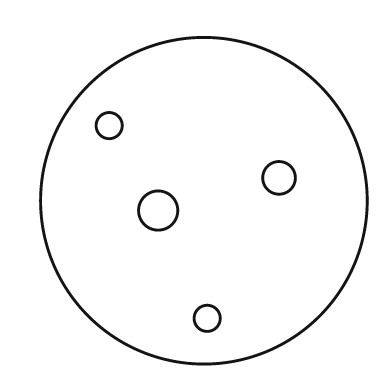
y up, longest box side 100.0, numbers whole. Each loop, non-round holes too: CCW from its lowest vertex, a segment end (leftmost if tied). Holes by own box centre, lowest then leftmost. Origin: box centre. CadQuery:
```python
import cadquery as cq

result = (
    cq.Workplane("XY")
    .moveTo(0.0, 0.0)
    .circle(50.0)
    .moveTo(1.0, -36.0)
    .circle(4.0)
    .moveTo(-14.0, -3.0)
    .circle(6.0)
    .moveTo(23.0, 7.0)
    .circle(5.0)
    .moveTo(-29.0, 23.0)
    .circle(4.0)
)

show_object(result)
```